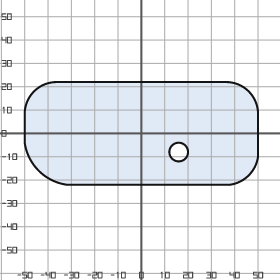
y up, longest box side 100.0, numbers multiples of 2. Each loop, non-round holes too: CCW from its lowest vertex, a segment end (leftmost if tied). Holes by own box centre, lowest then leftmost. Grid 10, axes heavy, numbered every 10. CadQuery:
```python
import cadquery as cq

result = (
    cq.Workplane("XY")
    .moveTo(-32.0, -22.0)
    .lineTo(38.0, -22.0)
    .threePointArc((46.0, -18.0), (50.0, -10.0))
    .lineTo(50.0, 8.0)
    .threePointArc((46.0, 18.0), (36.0, 22.0))
    .lineTo(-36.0, 22.0)
    .threePointArc((-46.0, 18.0), (-50.0, 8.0))
    .lineTo(-50.0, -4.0)
    .threePointArc((-44.0, -16.0), (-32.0, -22.0))
    .close()
    .moveTo(16.0, -8.0)
    .circle(4.0)
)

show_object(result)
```